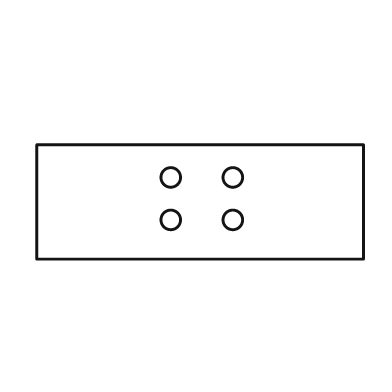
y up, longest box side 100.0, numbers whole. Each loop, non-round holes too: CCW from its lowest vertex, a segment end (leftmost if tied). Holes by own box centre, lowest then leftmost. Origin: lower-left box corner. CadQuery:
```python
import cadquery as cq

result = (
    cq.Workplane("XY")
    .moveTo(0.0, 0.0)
    .lineTo(100.0, 0.0)
    .lineTo(100.0, 35.0)
    .lineTo(0.0, 35.0)
    .close()
    .moveTo(41.0, 12.0)
    .circle(3.0)
    .moveTo(60.0, 12.0)
    .circle(3.0)
    .moveTo(41.0, 25.0)
    .circle(3.0)
    .moveTo(60.0, 25.0)
    .circle(3.0)
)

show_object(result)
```